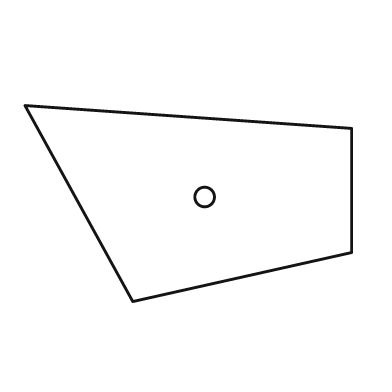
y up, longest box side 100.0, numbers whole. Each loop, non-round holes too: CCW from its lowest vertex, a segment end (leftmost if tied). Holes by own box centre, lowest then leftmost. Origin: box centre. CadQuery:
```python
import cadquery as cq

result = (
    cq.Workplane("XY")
    .moveTo(-17.0, -30.0)
    .lineTo(50.0, -15.0)
    .lineTo(50.0, 23.0)
    .lineTo(-50.0, 30.0)
    .close()
    .moveTo(5.0, 2.0)
    .circle(3.0)
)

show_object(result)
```